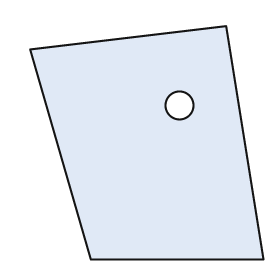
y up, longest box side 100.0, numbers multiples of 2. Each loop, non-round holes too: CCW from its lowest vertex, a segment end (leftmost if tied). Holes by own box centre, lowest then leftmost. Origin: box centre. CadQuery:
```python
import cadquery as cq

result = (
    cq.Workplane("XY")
    .moveTo(-24.0, -50.0)
    .lineTo(50.0, -50.0)
    .lineTo(34.0, 50.0)
    .lineTo(-50.0, 40.0)
    .close()
    .moveTo(14.0, 16.0)
    .circle(6.0)
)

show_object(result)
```